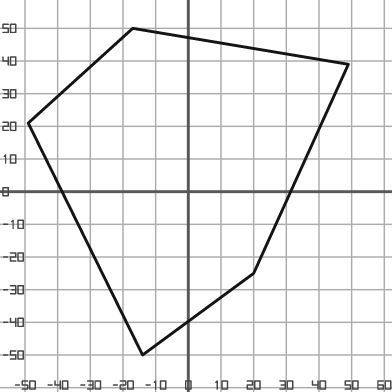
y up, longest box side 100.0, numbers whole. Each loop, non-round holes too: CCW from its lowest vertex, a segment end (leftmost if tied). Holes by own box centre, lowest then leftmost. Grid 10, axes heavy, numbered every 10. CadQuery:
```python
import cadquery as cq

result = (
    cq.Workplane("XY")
    .moveTo(-14.0, -50.0)
    .lineTo(20.0, -25.0)
    .lineTo(49.0, 39.0)
    .lineTo(-17.0, 50.0)
    .lineTo(-49.0, 21.0)
    .close()
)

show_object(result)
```